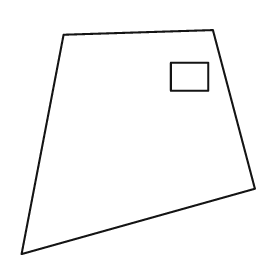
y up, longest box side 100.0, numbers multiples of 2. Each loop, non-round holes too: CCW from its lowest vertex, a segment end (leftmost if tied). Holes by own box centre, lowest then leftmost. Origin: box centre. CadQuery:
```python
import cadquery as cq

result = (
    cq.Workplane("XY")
    .moveTo(-50.0, -48.0)
    .lineTo(50.0, -20.0)
    .lineTo(32.0, 48.0)
    .lineTo(-32.0, 46.0)
    .close()
    .moveTo(14.0, 22.0)
    .lineTo(30.0, 22.0)
    .lineTo(30.0, 34.0)
    .lineTo(14.0, 34.0)
    .close()
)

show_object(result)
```